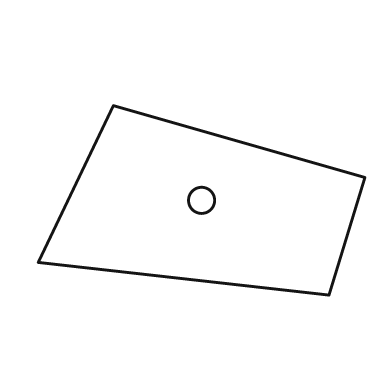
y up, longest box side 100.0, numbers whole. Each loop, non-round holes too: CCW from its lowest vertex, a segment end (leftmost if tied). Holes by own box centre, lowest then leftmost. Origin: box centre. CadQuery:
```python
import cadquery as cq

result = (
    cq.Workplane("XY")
    .moveTo(39.0, -29.0)
    .lineTo(50.0, 7.0)
    .lineTo(-27.0, 29.0)
    .lineTo(-50.0, -19.0)
    .close()
    .moveTo(0.0, 0.0)
    .circle(4.0)
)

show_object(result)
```